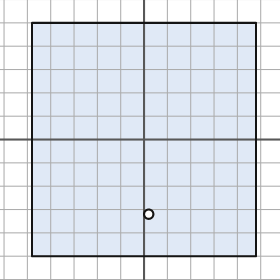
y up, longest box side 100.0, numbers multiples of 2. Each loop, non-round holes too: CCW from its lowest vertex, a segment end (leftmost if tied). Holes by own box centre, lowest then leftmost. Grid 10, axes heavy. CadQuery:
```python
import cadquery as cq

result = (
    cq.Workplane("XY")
    .moveTo(-48.0, -50.0)
    .lineTo(48.0, -50.0)
    .lineTo(48.0, 50.0)
    .lineTo(-48.0, 50.0)
    .close()
    .moveTo(2.0, -32.0)
    .circle(2.0)
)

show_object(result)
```